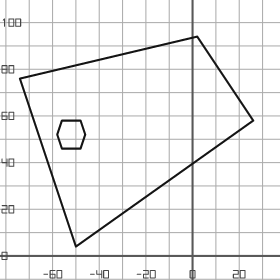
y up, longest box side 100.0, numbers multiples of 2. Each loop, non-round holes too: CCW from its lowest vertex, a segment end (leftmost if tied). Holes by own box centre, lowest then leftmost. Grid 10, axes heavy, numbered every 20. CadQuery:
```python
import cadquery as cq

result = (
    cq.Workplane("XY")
    .moveTo(-50.0, 4.0)
    .lineTo(26.0, 58.0)
    .lineTo(2.0, 94.0)
    .lineTo(-74.0, 76.0)
    .close()
    .moveTo(-56.0, 46.0)
    .lineTo(-48.0, 46.0)
    .lineTo(-46.0, 52.0)
    .lineTo(-48.0, 58.0)
    .lineTo(-56.0, 58.0)
    .lineTo(-58.0, 52.0)
    .close()
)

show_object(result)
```